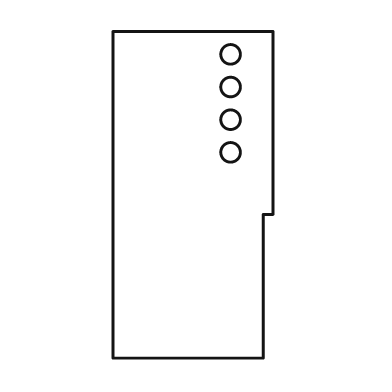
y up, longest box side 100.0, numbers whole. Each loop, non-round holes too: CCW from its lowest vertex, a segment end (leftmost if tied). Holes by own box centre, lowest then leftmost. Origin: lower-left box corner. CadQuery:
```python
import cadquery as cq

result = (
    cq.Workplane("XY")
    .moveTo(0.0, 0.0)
    .lineTo(46.0, 0.0)
    .lineTo(46.0, 44.0)
    .lineTo(49.0, 44.0)
    .lineTo(49.0, 100.0)
    .lineTo(0.0, 100.0)
    .close()
    .moveTo(36.0, 63.0)
    .circle(3.0)
    .moveTo(36.0, 73.0)
    .circle(3.0)
    .moveTo(36.0, 83.0)
    .circle(3.0)
    .moveTo(36.0, 93.0)
    .circle(3.0)
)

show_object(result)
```